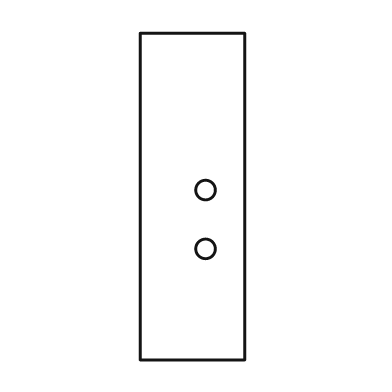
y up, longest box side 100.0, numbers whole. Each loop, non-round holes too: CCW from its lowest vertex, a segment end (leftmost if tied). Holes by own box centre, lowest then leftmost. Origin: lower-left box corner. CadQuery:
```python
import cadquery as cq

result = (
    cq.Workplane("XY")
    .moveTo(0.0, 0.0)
    .lineTo(32.0, 0.0)
    .lineTo(32.0, 100.0)
    .lineTo(0.0, 100.0)
    .close()
    .moveTo(20.0, 34.0)
    .circle(3.0)
    .moveTo(20.0, 52.0)
    .circle(3.0)
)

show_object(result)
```